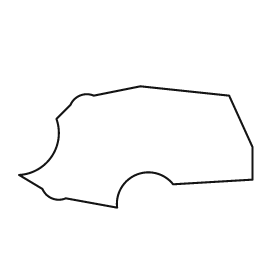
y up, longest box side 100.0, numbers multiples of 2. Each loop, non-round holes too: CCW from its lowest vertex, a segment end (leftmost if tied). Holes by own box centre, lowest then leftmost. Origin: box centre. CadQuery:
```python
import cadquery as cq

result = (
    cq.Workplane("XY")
    .moveTo(-8.0, -26.0)
    .threePointArc((0.0, -12.0), (16.0, -16.0))
    .lineTo(50.0, -14.0)
    .lineTo(50.0, 0.0)
    .lineTo(40.0, 22.0)
    .lineTo(2.0, 26.0)
    .lineTo(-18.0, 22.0)
    .threePointArc((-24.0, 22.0), (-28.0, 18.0))
    .lineTo(-34.0, 12.0)
    .threePointArc((-36.0, -4.0), (-50.0, -12.0))
    .lineTo(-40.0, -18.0)
    .threePointArc((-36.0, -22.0), (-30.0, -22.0))
    .close()
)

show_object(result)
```